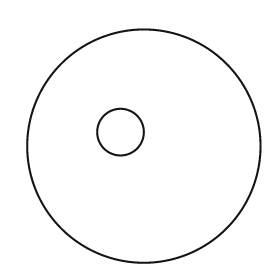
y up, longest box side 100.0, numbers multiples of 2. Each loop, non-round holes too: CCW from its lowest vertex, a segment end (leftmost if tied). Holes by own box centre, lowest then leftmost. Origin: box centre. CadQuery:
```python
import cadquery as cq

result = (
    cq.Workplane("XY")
    .moveTo(0.0, 0.0)
    .circle(50.0)
    .moveTo(-10.0, 6.0)
    .circle(10.0)
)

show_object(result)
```